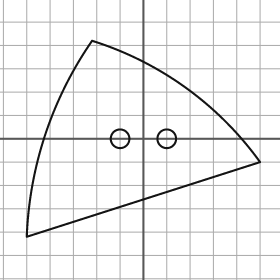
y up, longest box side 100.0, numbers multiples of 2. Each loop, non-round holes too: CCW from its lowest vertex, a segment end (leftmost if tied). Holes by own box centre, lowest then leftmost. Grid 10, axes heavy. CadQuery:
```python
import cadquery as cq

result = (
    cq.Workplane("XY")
    .moveTo(-50.0, -42.0)
    .lineTo(50.0, -10.0)
    .threePointArc((18.0, 22.0), (-22.0, 42.0))
    .threePointArc((-42.0, 2.0), (-50.0, -42.0))
    .close()
    .moveTo(-10.0, 0.0)
    .circle(4.0)
    .moveTo(10.0, 0.0)
    .circle(4.0)
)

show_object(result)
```